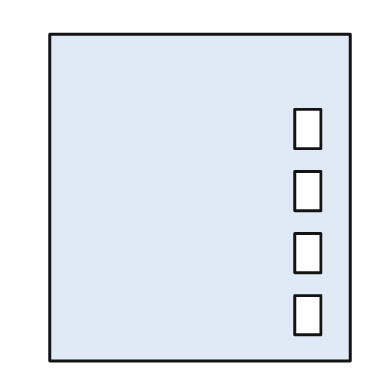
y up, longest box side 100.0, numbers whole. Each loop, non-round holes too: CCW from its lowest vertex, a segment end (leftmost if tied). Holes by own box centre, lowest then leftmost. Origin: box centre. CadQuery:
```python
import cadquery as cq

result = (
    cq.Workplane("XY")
    .moveTo(-46.0, -50.0)
    .lineTo(46.0, -50.0)
    .lineTo(46.0, 50.0)
    .lineTo(-46.0, 50.0)
    .close()
    .moveTo(29.0, -42.0)
    .lineTo(37.0, -42.0)
    .lineTo(37.0, -30.0)
    .lineTo(29.0, -30.0)
    .close()
    .moveTo(29.0, -23.0)
    .lineTo(37.0, -23.0)
    .lineTo(37.0, -11.0)
    .lineTo(29.0, -11.0)
    .close()
    .moveTo(29.0, -4.0)
    .lineTo(37.0, -4.0)
    .lineTo(37.0, 8.0)
    .lineTo(29.0, 8.0)
    .close()
    .moveTo(29.0, 15.0)
    .lineTo(37.0, 15.0)
    .lineTo(37.0, 27.0)
    .lineTo(29.0, 27.0)
    .close()
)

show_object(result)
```